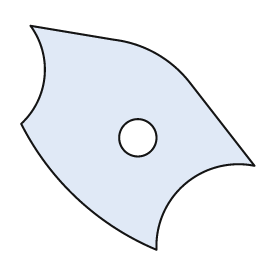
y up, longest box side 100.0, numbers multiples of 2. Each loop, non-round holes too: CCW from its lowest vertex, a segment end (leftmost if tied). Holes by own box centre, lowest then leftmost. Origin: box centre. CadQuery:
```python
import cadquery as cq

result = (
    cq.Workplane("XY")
    .moveTo(8.0, -48.0)
    .threePointArc((20.0, -20.0), (50.0, -12.0))
    .lineTo(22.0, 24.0)
    .threePointArc((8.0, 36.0), (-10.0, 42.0))
    .lineTo(-46.0, 48.0)
    .threePointArc((-40.0, 26.0), (-50.0, 6.0))
    .threePointArc((-26.0, -26.0), (8.0, -48.0))
    .close()
    .moveTo(0.0, 0.0)
    .circle(8.0)
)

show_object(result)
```